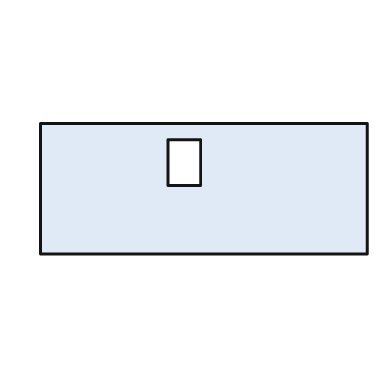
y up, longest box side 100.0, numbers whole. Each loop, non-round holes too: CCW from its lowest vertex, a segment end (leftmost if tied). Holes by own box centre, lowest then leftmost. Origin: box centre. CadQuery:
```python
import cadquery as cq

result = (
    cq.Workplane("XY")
    .moveTo(-50.0, -20.0)
    .lineTo(50.0, -20.0)
    .lineTo(50.0, 20.0)
    .lineTo(-50.0, 20.0)
    .close()
    .moveTo(-11.0, 1.0)
    .lineTo(-1.0, 1.0)
    .lineTo(-1.0, 15.0)
    .lineTo(-11.0, 15.0)
    .close()
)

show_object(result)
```